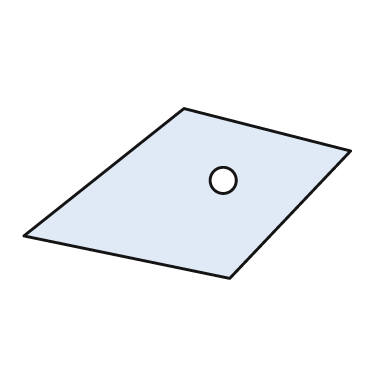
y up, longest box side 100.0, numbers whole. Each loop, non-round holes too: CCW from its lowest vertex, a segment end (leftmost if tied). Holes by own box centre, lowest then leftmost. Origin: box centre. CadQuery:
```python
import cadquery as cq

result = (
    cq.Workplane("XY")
    .moveTo(13.0, -26.0)
    .lineTo(50.0, 13.0)
    .lineTo(-1.0, 26.0)
    .lineTo(-50.0, -13.0)
    .close()
    .moveTo(11.0, 4.0)
    .circle(4.0)
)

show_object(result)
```